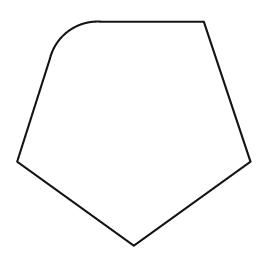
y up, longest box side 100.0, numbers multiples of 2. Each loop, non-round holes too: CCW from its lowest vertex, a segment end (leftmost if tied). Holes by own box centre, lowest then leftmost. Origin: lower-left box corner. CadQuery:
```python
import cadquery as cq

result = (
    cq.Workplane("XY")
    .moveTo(50.0, 0.0)
    .lineTo(100.0, 36.0)
    .lineTo(80.0, 96.0)
    .lineTo(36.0, 96.0)
    .threePointArc((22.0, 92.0), (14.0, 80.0))
    .lineTo(0.0, 36.0)
    .close()
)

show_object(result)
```